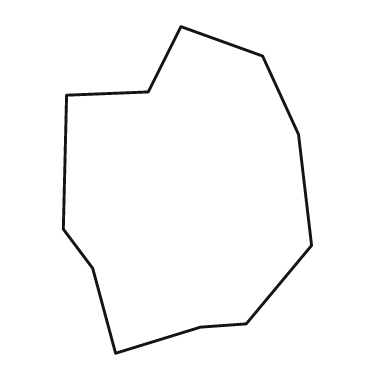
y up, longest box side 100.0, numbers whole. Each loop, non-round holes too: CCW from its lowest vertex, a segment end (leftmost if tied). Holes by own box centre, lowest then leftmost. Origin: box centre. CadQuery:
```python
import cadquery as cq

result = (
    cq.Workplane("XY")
    .moveTo(-22.0, -50.0)
    .lineTo(4.0, -42.0)
    .lineTo(18.0, -41.0)
    .lineTo(38.0, -17.0)
    .lineTo(34.0, 17.0)
    .lineTo(23.0, 41.0)
    .lineTo(-2.0, 50.0)
    .lineTo(-12.0, 30.0)
    .lineTo(-37.0, 29.0)
    .lineTo(-38.0, -12.0)
    .lineTo(-29.0, -24.0)
    .close()
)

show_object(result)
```